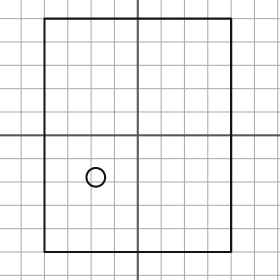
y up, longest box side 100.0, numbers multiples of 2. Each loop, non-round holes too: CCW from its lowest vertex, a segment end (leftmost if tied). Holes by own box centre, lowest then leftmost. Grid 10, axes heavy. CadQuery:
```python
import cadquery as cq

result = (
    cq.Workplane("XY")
    .moveTo(-40.0, -50.0)
    .lineTo(40.0, -50.0)
    .lineTo(40.0, 50.0)
    .lineTo(-40.0, 50.0)
    .close()
    .moveTo(-18.0, -18.0)
    .circle(4.0)
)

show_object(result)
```